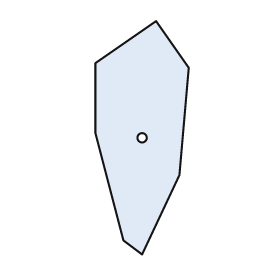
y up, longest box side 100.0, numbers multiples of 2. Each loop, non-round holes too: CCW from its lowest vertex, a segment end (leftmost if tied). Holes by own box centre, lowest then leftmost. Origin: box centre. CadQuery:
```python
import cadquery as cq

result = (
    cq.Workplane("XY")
    .moveTo(0.0, -50.0)
    .lineTo(16.0, -16.0)
    .lineTo(20.0, 30.0)
    .lineTo(6.0, 50.0)
    .lineTo(-20.0, 32.0)
    .lineTo(-20.0, 2.0)
    .lineTo(-8.0, -44.0)
    .close()
    .moveTo(0.0, 0.0)
    .circle(2.0)
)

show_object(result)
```